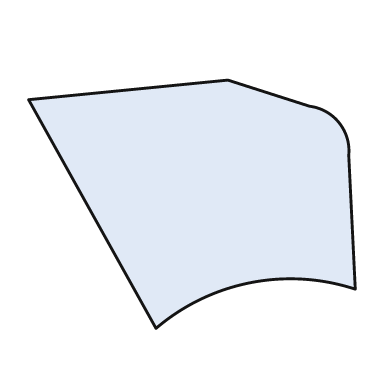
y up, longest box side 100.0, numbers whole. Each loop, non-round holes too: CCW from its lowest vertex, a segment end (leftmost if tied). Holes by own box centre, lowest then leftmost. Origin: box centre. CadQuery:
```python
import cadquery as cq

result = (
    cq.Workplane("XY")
    .moveTo(-11.0, -38.0)
    .threePointArc((18.0, -24.0), (50.0, -26.0))
    .lineTo(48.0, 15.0)
    .threePointArc((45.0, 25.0), (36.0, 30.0))
    .lineTo(11.0, 38.0)
    .lineTo(-50.0, 32.0)
    .close()
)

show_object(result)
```